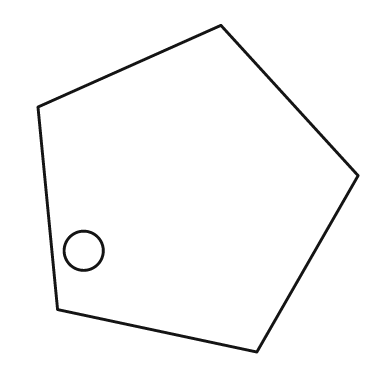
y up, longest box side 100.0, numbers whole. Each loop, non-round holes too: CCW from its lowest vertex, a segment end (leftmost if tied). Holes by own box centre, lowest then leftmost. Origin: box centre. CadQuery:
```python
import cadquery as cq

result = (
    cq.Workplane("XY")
    .moveTo(18.0, -50.0)
    .lineTo(49.0, 4.0)
    .lineTo(7.0, 50.0)
    .lineTo(-49.0, 25.0)
    .lineTo(-43.0, -37.0)
    .close()
    .moveTo(-35.0, -19.0)
    .circle(6.0)
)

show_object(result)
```